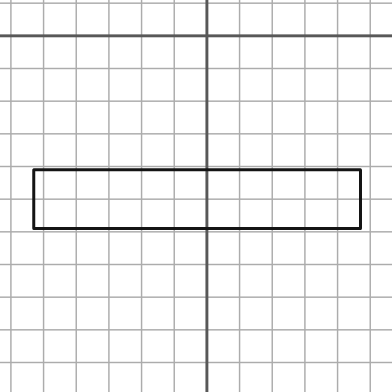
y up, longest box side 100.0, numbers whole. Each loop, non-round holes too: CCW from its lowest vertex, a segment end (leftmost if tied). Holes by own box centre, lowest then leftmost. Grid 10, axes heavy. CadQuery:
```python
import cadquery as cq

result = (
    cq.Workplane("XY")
    .moveTo(-53.0, -59.0)
    .lineTo(47.0, -59.0)
    .lineTo(47.0, -41.0)
    .lineTo(-53.0, -41.0)
    .close()
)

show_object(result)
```